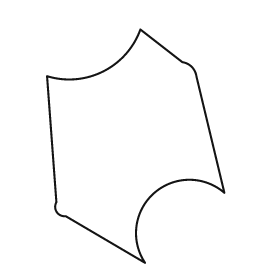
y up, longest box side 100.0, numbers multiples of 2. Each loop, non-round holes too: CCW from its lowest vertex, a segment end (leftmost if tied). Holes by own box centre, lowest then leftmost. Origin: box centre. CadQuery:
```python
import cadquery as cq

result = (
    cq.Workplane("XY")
    .moveTo(4.0, -50.0)
    .threePointArc((8.0, -20.0), (38.0, -20.0))
    .lineTo(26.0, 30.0)
    .threePointArc((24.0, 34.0), (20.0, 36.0))
    .lineTo(2.0, 50.0)
    .threePointArc((-14.0, 32.0), (-38.0, 30.0))
    .lineTo(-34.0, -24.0)
    .threePointArc((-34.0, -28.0), (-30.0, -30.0))
    .close()
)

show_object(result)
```